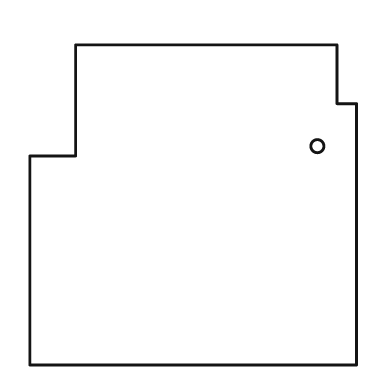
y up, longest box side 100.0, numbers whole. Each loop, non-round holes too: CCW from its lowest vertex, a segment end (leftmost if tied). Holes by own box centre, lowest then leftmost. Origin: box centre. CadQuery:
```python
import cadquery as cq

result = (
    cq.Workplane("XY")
    .moveTo(-50.0, -49.0)
    .lineTo(50.0, -49.0)
    .lineTo(50.0, 31.0)
    .lineTo(44.0, 31.0)
    .lineTo(44.0, 49.0)
    .lineTo(-36.0, 49.0)
    .lineTo(-36.0, 15.0)
    .lineTo(-50.0, 15.0)
    .close()
    .moveTo(38.0, 18.0)
    .circle(2.0)
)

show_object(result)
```